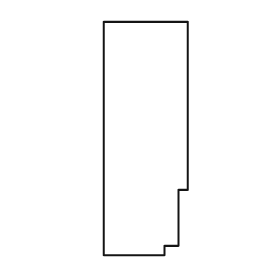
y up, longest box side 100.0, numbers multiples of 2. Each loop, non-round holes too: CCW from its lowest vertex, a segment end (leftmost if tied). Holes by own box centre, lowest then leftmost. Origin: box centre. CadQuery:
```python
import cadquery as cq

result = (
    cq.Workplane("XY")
    .moveTo(-18.0, -50.0)
    .lineTo(8.0, -50.0)
    .lineTo(8.0, -46.0)
    .lineTo(14.0, -46.0)
    .lineTo(14.0, -22.0)
    .lineTo(18.0, -22.0)
    .lineTo(18.0, 50.0)
    .lineTo(-18.0, 50.0)
    .close()
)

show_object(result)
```